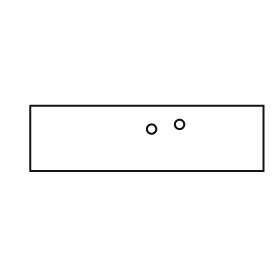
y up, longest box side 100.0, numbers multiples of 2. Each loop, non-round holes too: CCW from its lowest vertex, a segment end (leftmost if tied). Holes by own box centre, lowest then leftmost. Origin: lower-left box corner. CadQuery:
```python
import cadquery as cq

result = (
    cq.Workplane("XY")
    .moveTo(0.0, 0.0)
    .lineTo(100.0, 0.0)
    .lineTo(100.0, 28.0)
    .lineTo(0.0, 28.0)
    .close()
    .moveTo(52.0, 18.0)
    .circle(2.0)
    .moveTo(64.0, 20.0)
    .circle(2.0)
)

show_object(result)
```